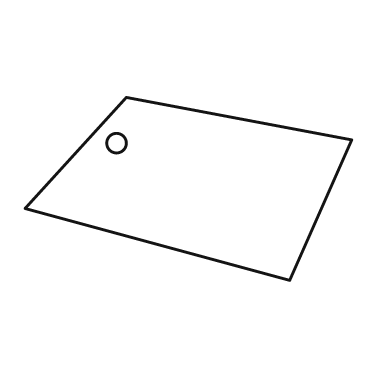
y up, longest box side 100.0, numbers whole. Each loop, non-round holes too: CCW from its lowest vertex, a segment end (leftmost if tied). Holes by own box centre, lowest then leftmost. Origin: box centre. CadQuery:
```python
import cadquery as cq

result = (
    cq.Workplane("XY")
    .moveTo(31.0, -28.0)
    .lineTo(50.0, 15.0)
    .lineTo(-19.0, 28.0)
    .lineTo(-50.0, -6.0)
    .close()
    .moveTo(-22.0, 14.0)
    .circle(3.0)
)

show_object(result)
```